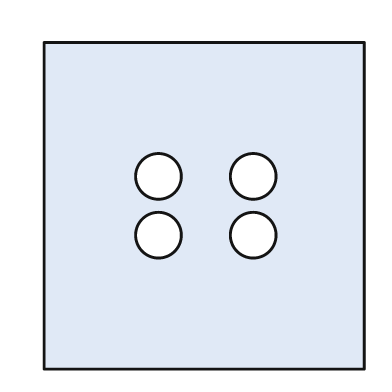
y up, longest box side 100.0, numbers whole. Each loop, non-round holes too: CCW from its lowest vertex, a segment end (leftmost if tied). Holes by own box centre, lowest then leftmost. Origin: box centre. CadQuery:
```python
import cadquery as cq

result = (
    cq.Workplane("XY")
    .moveTo(-49.0, -50.0)
    .lineTo(49.0, -50.0)
    .lineTo(49.0, 50.0)
    .lineTo(-49.0, 50.0)
    .close()
    .moveTo(-14.0, -9.0)
    .circle(7.0)
    .moveTo(15.0, -9.0)
    .circle(7.0)
    .moveTo(-14.0, 9.0)
    .circle(7.0)
    .moveTo(15.0, 9.0)
    .circle(7.0)
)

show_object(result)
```